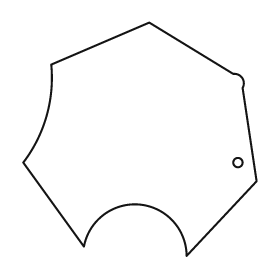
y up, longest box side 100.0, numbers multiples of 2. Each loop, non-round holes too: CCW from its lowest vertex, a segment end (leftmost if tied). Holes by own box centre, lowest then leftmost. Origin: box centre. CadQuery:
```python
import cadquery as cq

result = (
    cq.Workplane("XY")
    .moveTo(20.0, -50.0)
    .lineTo(50.0, -18.0)
    .lineTo(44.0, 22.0)
    .threePointArc((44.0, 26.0), (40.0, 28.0))
    .lineTo(4.0, 50.0)
    .lineTo(-38.0, 32.0)
    .threePointArc((-40.0, 10.0), (-50.0, -10.0))
    .lineTo(-24.0, -46.0)
    .threePointArc((0.0, -28.0), (20.0, -50.0))
    .close()
    .moveTo(42.0, -10.0)
    .circle(2.0)
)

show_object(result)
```